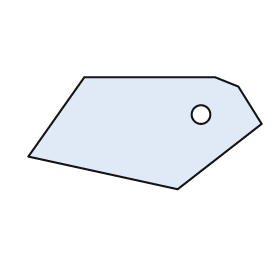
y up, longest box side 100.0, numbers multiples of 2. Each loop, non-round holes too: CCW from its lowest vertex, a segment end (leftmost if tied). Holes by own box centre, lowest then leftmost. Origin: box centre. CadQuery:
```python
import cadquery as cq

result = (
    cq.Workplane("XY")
    .moveTo(14.0, -24.0)
    .lineTo(50.0, 4.0)
    .lineTo(40.0, 20.0)
    .lineTo(30.0, 24.0)
    .lineTo(-26.0, 24.0)
    .lineTo(-50.0, -10.0)
    .close()
    .moveTo(24.0, 8.0)
    .circle(4.0)
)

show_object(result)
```